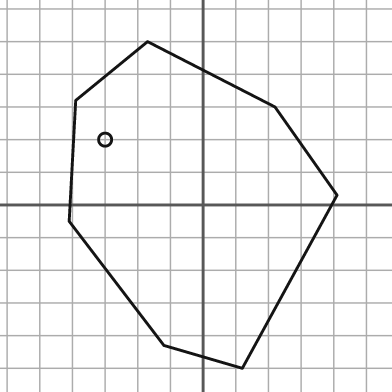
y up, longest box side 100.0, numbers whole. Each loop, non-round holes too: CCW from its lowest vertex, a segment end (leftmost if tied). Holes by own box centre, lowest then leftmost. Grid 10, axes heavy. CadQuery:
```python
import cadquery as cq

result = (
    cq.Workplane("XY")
    .moveTo(12.0, -50.0)
    .lineTo(41.0, 3.0)
    .lineTo(22.0, 30.0)
    .lineTo(-17.0, 50.0)
    .lineTo(-39.0, 32.0)
    .lineTo(-41.0, -5.0)
    .lineTo(-12.0, -43.0)
    .close()
    .moveTo(-30.0, 20.0)
    .circle(2.0)
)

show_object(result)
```